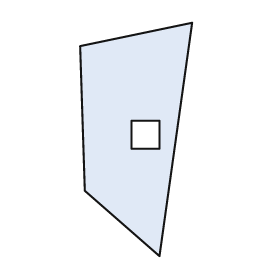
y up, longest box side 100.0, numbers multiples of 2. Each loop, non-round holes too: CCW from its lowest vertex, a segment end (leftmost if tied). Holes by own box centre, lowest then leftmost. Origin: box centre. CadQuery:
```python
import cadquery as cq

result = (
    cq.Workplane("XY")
    .moveTo(10.0, -50.0)
    .lineTo(24.0, 50.0)
    .lineTo(-24.0, 40.0)
    .lineTo(-22.0, -22.0)
    .close()
    .moveTo(-2.0, -4.0)
    .lineTo(10.0, -4.0)
    .lineTo(10.0, 8.0)
    .lineTo(-2.0, 8.0)
    .close()
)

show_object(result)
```